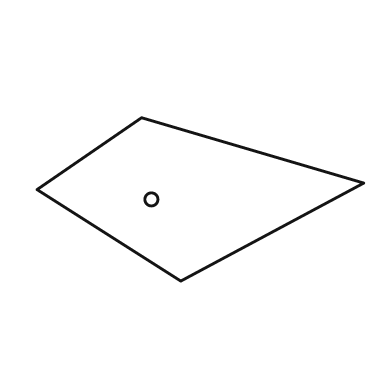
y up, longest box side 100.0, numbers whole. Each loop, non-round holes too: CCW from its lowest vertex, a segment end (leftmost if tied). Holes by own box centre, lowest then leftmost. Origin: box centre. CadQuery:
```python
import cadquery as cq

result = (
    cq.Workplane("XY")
    .moveTo(-6.0, -25.0)
    .lineTo(50.0, 5.0)
    .lineTo(-18.0, 25.0)
    .lineTo(-50.0, 3.0)
    .close()
    .moveTo(-15.0, 0.0)
    .circle(2.0)
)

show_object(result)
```